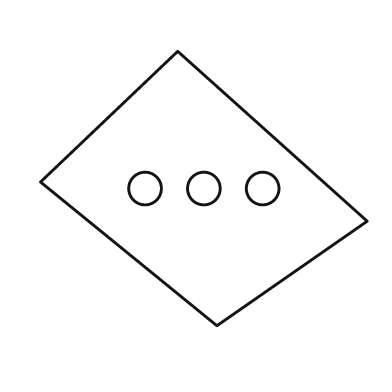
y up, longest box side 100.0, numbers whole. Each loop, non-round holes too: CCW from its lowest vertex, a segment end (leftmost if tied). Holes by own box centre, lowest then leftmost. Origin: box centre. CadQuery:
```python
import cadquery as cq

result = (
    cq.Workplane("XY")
    .moveTo(4.0, -42.0)
    .lineTo(50.0, -10.0)
    .lineTo(-8.0, 42.0)
    .lineTo(-50.0, 2.0)
    .close()
    .moveTo(-18.0, 0.0)
    .circle(5.0)
    .moveTo(0.0, 0.0)
    .circle(5.0)
    .moveTo(18.0, 0.0)
    .circle(5.0)
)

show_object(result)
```